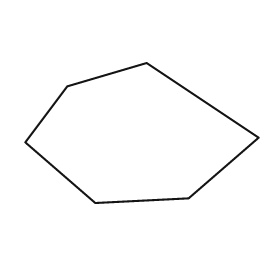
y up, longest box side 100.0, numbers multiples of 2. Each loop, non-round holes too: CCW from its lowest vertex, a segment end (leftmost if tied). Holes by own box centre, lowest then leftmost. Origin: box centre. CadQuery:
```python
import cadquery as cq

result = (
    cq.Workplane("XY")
    .moveTo(-20.0, -30.0)
    .lineTo(20.0, -28.0)
    .lineTo(50.0, -2.0)
    .lineTo(2.0, 30.0)
    .lineTo(-32.0, 20.0)
    .lineTo(-50.0, -4.0)
    .close()
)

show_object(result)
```